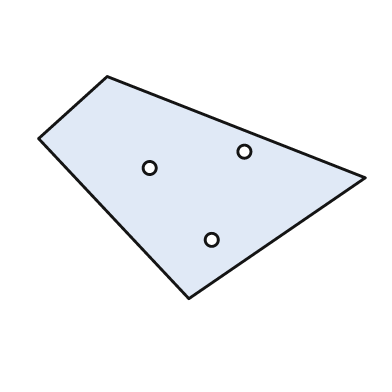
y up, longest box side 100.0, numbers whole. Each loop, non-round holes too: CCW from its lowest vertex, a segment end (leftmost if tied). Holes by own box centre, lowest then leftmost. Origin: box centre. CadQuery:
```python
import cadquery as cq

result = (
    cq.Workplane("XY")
    .moveTo(-4.0, -34.0)
    .lineTo(50.0, 3.0)
    .lineTo(-29.0, 34.0)
    .lineTo(-50.0, 15.0)
    .close()
    .moveTo(3.0, -16.0)
    .circle(2.0)
    .moveTo(-16.0, 6.0)
    .circle(2.0)
    .moveTo(13.0, 11.0)
    .circle(2.0)
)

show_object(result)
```